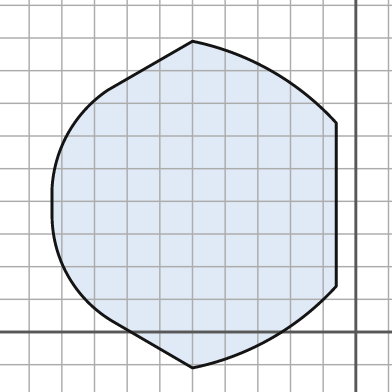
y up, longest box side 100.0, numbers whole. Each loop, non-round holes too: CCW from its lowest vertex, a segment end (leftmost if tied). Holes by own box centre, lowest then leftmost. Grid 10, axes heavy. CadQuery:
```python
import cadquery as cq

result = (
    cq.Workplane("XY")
    .moveTo(-50.0, -11.0)
    .threePointArc((-26.0, -2.0), (-6.0, 14.0))
    .lineTo(-6.0, 64.0)
    .threePointArc((-26.0, 80.0), (-50.0, 89.0))
    .lineTo(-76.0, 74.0)
    .threePointArc((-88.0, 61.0), (-93.0, 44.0))
    .lineTo(-93.0, 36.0)
    .threePointArc((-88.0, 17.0), (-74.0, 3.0))
    .close()
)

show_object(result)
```